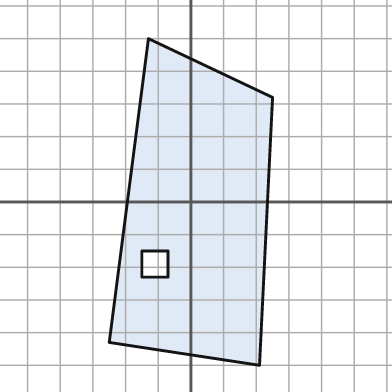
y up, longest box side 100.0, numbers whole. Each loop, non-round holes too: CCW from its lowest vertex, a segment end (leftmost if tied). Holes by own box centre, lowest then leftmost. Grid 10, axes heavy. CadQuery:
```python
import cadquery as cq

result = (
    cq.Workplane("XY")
    .moveTo(21.0, -50.0)
    .lineTo(25.0, 32.0)
    .lineTo(-13.0, 50.0)
    .lineTo(-25.0, -43.0)
    .close()
    .moveTo(-15.0, -23.0)
    .lineTo(-7.0, -23.0)
    .lineTo(-7.0, -15.0)
    .lineTo(-15.0, -15.0)
    .close()
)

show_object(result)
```